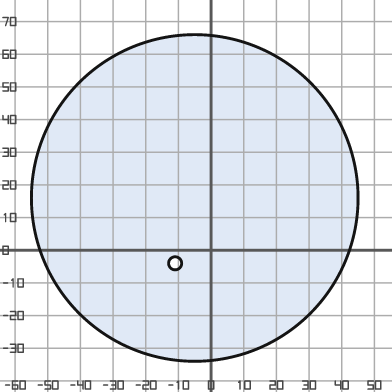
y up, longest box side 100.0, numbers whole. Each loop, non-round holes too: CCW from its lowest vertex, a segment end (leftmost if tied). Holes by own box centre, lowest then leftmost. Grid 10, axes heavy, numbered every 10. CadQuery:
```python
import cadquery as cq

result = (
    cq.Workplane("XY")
    .moveTo(-5.0, 16.0)
    .circle(50.0)
    .moveTo(-11.0, -4.0)
    .circle(2.0)
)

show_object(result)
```